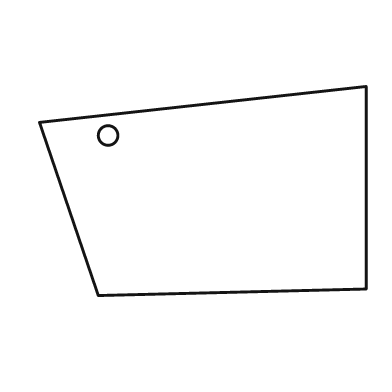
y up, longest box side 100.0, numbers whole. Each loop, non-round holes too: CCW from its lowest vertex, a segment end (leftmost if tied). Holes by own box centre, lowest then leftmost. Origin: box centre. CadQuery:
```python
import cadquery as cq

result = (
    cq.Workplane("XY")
    .moveTo(-32.0, -32.0)
    .lineTo(50.0, -30.0)
    .lineTo(50.0, 32.0)
    .lineTo(-50.0, 21.0)
    .close()
    .moveTo(-29.0, 17.0)
    .circle(3.0)
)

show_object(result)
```